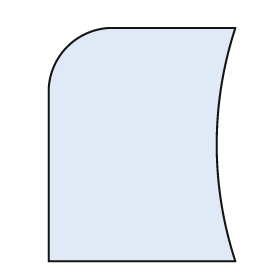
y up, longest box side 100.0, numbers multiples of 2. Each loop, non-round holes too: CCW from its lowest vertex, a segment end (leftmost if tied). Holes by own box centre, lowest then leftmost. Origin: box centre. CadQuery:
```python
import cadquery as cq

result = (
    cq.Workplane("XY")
    .moveTo(-40.0, -50.0)
    .lineTo(40.0, -50.0)
    .threePointArc((32.0, 0.0), (40.0, 50.0))
    .lineTo(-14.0, 50.0)
    .threePointArc((-32.0, 42.0), (-40.0, 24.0))
    .close()
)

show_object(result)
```